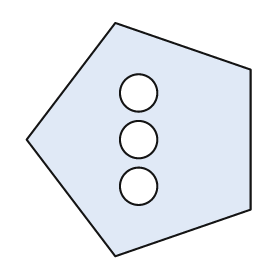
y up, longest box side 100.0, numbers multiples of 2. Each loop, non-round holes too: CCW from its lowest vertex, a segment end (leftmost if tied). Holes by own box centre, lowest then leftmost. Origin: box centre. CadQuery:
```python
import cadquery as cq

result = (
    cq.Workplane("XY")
    .moveTo(-10.0, -50.0)
    .lineTo(48.0, -30.0)
    .lineTo(48.0, 30.0)
    .lineTo(-10.0, 50.0)
    .lineTo(-48.0, 0.0)
    .close()
    .moveTo(0.0, -20.0)
    .circle(8.0)
    .moveTo(0.0, 0.0)
    .circle(8.0)
    .moveTo(0.0, 20.0)
    .circle(8.0)
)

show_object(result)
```